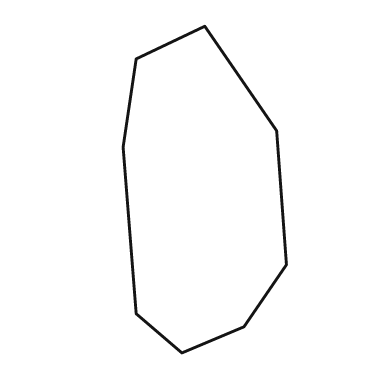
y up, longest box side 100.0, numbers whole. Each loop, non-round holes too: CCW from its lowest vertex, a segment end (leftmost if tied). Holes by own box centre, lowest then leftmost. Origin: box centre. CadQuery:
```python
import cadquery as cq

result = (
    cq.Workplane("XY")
    .moveTo(-7.0, -50.0)
    .lineTo(12.0, -42.0)
    .lineTo(25.0, -23.0)
    .lineTo(22.0, 18.0)
    .lineTo(0.0, 50.0)
    .lineTo(-21.0, 40.0)
    .lineTo(-25.0, 13.0)
    .lineTo(-21.0, -38.0)
    .close()
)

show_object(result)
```